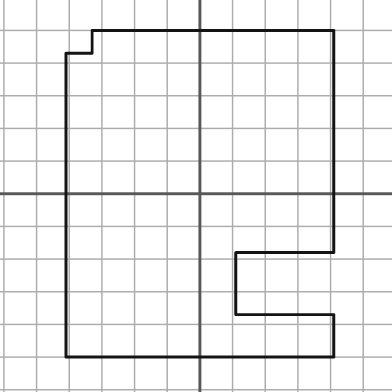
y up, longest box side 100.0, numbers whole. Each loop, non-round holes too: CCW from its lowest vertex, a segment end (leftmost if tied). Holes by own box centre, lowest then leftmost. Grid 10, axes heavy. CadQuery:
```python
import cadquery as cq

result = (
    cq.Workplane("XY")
    .moveTo(-41.0, -50.0)
    .lineTo(41.0, -50.0)
    .lineTo(41.0, -37.0)
    .lineTo(11.0, -37.0)
    .lineTo(11.0, -18.0)
    .lineTo(41.0, -18.0)
    .lineTo(41.0, 50.0)
    .lineTo(-33.0, 50.0)
    .lineTo(-33.0, 43.0)
    .lineTo(-41.0, 43.0)
    .close()
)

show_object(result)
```